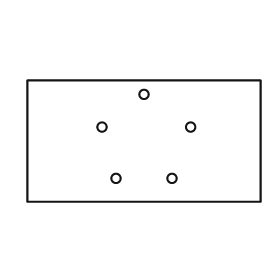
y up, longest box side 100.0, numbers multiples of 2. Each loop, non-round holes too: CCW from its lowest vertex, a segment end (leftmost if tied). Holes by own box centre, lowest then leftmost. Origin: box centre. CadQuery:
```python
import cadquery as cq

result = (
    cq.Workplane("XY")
    .moveTo(-50.0, -26.0)
    .lineTo(50.0, -26.0)
    .lineTo(50.0, 26.0)
    .lineTo(-50.0, 26.0)
    .close()
    .moveTo(-12.0, -16.0)
    .circle(2.0)
    .moveTo(12.0, -16.0)
    .circle(2.0)
    .moveTo(-18.0, 6.0)
    .circle(2.0)
    .moveTo(20.0, 6.0)
    .circle(2.0)
    .moveTo(0.0, 20.0)
    .circle(2.0)
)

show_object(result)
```